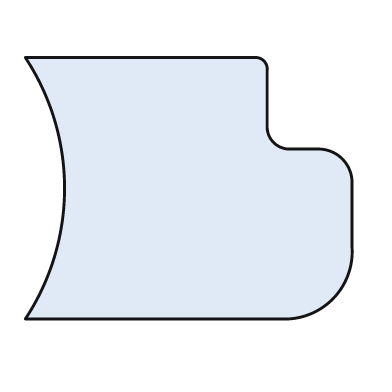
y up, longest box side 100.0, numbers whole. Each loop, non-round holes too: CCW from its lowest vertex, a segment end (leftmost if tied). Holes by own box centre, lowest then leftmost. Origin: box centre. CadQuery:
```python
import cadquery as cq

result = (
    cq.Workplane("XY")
    .moveTo(-50.0, -40.0)
    .lineTo(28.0, -40.0)
    .threePointArc((44.0, -34.0), (50.0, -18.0))
    .lineTo(50.0, 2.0)
    .threePointArc((47.0, 9.0), (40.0, 12.0))
    .lineTo(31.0, 12.0)
    .threePointArc((26.0, 14.0), (24.0, 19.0))
    .lineTo(24.0, 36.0)
    .threePointArc((23.0, 39.0), (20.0, 40.0))
    .lineTo(-50.0, 40.0)
    .threePointArc((-38.0, 0.0), (-50.0, -40.0))
    .close()
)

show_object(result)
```